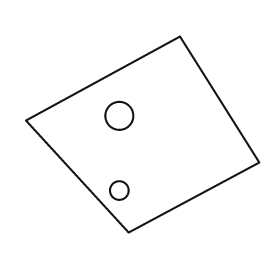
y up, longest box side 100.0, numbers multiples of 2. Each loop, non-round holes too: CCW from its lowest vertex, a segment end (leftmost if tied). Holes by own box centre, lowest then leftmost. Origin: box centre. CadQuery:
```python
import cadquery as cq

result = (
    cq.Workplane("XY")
    .moveTo(-6.0, -42.0)
    .lineTo(50.0, -12.0)
    .lineTo(16.0, 42.0)
    .lineTo(-50.0, 6.0)
    .close()
    .moveTo(-10.0, -24.0)
    .circle(4.0)
    .moveTo(-10.0, 8.0)
    .circle(6.0)
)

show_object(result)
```